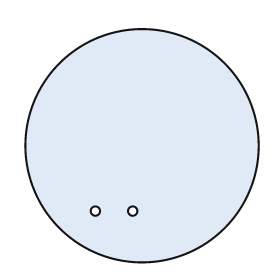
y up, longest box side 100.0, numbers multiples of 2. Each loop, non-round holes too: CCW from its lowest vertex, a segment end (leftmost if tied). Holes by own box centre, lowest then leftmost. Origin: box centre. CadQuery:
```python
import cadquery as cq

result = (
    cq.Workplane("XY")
    .moveTo(0.0, 0.0)
    .circle(50.0)
    .moveTo(-20.0, -28.0)
    .circle(2.0)
    .moveTo(-4.0, -28.0)
    .circle(2.0)
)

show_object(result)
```